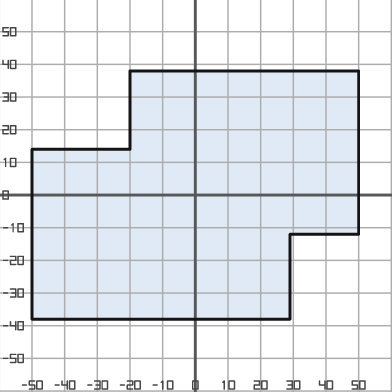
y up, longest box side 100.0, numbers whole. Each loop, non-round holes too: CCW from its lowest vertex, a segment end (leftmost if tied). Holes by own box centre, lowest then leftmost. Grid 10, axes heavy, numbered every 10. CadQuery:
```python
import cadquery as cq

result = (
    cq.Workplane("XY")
    .moveTo(-50.0, -38.0)
    .lineTo(29.0, -38.0)
    .lineTo(29.0, -12.0)
    .lineTo(50.0, -12.0)
    .lineTo(50.0, 38.0)
    .lineTo(-20.0, 38.0)
    .lineTo(-20.0, 14.0)
    .lineTo(-50.0, 14.0)
    .close()
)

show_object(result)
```